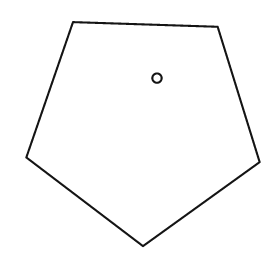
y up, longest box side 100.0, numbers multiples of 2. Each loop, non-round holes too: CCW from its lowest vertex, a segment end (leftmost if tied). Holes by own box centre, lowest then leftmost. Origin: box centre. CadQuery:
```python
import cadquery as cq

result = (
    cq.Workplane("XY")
    .moveTo(0.0, -48.0)
    .lineTo(50.0, -12.0)
    .lineTo(32.0, 46.0)
    .lineTo(-30.0, 48.0)
    .lineTo(-50.0, -10.0)
    .close()
    .moveTo(6.0, 24.0)
    .circle(2.0)
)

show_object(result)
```